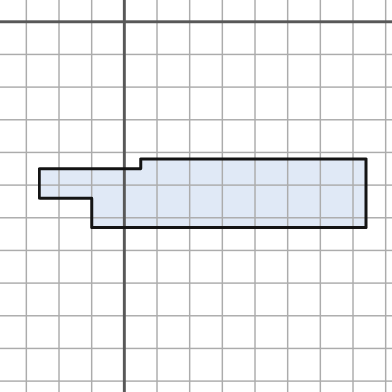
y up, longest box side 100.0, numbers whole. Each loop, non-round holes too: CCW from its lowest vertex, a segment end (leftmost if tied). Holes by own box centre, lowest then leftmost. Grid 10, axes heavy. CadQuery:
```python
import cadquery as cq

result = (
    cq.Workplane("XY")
    .moveTo(-10.0, -63.0)
    .lineTo(74.0, -63.0)
    .lineTo(74.0, -42.0)
    .lineTo(5.0, -42.0)
    .lineTo(5.0, -45.0)
    .lineTo(-26.0, -45.0)
    .lineTo(-26.0, -54.0)
    .lineTo(-10.0, -54.0)
    .close()
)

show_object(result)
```